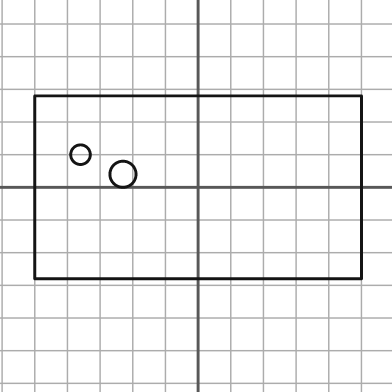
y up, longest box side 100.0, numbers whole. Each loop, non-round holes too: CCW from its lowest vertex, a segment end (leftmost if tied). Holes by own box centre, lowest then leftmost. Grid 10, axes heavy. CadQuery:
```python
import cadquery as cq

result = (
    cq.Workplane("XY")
    .moveTo(-50.0, -28.0)
    .lineTo(50.0, -28.0)
    .lineTo(50.0, 28.0)
    .lineTo(-50.0, 28.0)
    .close()
    .moveTo(-23.0, 4.0)
    .circle(4.0)
    .moveTo(-36.0, 10.0)
    .circle(3.0)
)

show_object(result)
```